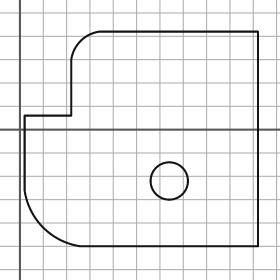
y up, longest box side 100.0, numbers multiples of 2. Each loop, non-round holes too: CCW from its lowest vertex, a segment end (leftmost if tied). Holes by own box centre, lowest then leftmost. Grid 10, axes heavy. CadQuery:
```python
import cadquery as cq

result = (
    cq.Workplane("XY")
    .moveTo(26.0, -50.0)
    .lineTo(102.0, -50.0)
    .lineTo(102.0, 42.0)
    .lineTo(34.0, 42.0)
    .threePointArc((26.0, 38.0), (22.0, 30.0))
    .lineTo(22.0, 6.0)
    .lineTo(2.0, 6.0)
    .lineTo(2.0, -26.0)
    .threePointArc((10.0, -42.0), (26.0, -50.0))
    .close()
    .moveTo(64.0, -22.0)
    .circle(8.0)
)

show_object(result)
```